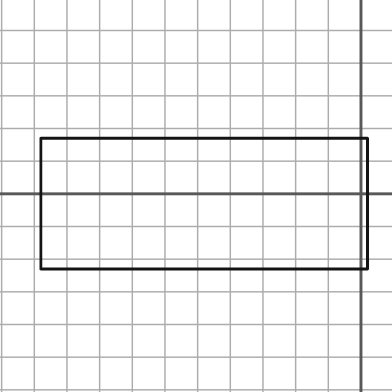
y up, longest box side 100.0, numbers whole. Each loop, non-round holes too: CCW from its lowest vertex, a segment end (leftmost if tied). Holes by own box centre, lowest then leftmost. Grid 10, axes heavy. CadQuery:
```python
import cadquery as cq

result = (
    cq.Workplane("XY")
    .moveTo(-98.0, -23.0)
    .lineTo(2.0, -23.0)
    .lineTo(2.0, 17.0)
    .lineTo(-98.0, 17.0)
    .close()
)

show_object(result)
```